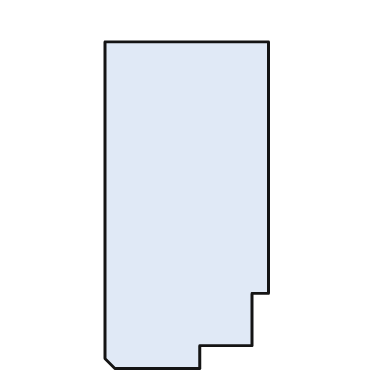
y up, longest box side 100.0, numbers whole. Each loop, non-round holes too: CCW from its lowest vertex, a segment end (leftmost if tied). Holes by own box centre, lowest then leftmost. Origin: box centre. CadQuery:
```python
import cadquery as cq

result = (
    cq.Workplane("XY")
    .moveTo(-22.0, -50.0)
    .lineTo(4.0, -50.0)
    .lineTo(4.0, -43.0)
    .lineTo(20.0, -43.0)
    .lineTo(20.0, -27.0)
    .lineTo(25.0, -27.0)
    .lineTo(25.0, 50.0)
    .lineTo(-25.0, 50.0)
    .lineTo(-25.0, -47.0)
    .close()
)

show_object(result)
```